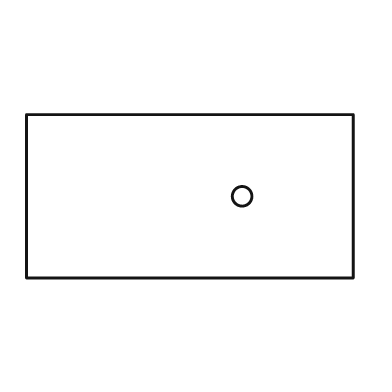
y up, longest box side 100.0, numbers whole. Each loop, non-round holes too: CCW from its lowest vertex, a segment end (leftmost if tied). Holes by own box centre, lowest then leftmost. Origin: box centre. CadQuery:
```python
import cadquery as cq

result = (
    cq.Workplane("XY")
    .moveTo(-50.0, -25.0)
    .lineTo(50.0, -25.0)
    .lineTo(50.0, 25.0)
    .lineTo(-50.0, 25.0)
    .close()
    .moveTo(16.0, 0.0)
    .circle(3.0)
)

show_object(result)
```